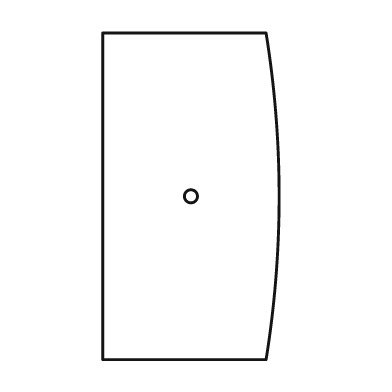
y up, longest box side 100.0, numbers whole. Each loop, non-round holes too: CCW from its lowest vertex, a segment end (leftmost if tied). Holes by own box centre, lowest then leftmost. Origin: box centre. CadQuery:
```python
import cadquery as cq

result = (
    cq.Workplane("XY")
    .moveTo(-27.0, -50.0)
    .lineTo(23.0, -50.0)
    .threePointArc((27.0, 0.0), (23.0, 50.0))
    .lineTo(-27.0, 50.0)
    .close()
    .moveTo(0.0, 0.0)
    .circle(2.0)
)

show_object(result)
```